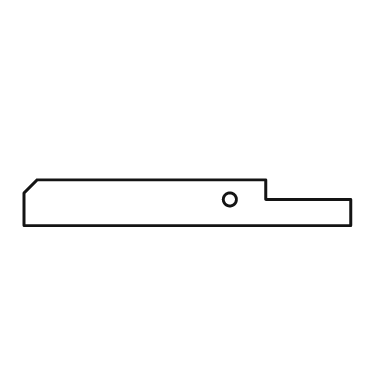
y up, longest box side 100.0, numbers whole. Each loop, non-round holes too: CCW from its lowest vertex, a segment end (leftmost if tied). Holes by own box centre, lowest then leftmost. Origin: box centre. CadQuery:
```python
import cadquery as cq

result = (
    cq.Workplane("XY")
    .moveTo(-50.0, -7.0)
    .lineTo(50.0, -7.0)
    .lineTo(50.0, 1.0)
    .lineTo(24.0, 1.0)
    .lineTo(24.0, 7.0)
    .lineTo(-46.0, 7.0)
    .lineTo(-50.0, 3.0)
    .close()
    .moveTo(13.0, 1.0)
    .circle(2.0)
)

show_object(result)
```